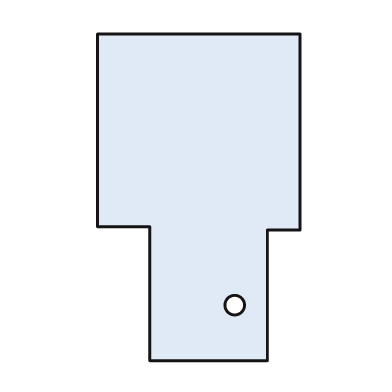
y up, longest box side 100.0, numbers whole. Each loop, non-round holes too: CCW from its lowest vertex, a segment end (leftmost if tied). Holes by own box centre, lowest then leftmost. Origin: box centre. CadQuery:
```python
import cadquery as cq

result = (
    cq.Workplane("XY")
    .moveTo(-15.0, -50.0)
    .lineTo(21.0, -50.0)
    .lineTo(21.0, -10.0)
    .lineTo(31.0, -10.0)
    .lineTo(31.0, 50.0)
    .lineTo(-31.0, 50.0)
    .lineTo(-31.0, -9.0)
    .lineTo(-15.0, -9.0)
    .close()
    .moveTo(11.0, -33.0)
    .circle(3.0)
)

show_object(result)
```